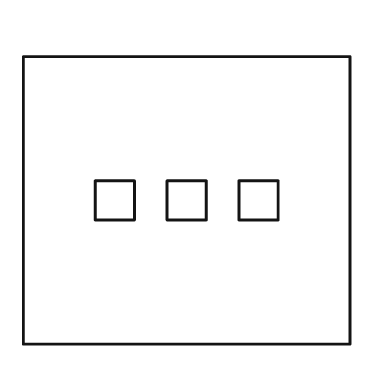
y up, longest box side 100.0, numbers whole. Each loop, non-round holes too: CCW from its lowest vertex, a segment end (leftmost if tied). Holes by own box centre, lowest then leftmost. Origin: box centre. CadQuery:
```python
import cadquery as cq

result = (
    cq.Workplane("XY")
    .moveTo(-50.0, -44.0)
    .lineTo(50.0, -44.0)
    .lineTo(50.0, 44.0)
    .lineTo(-50.0, 44.0)
    .close()
    .moveTo(-28.0, -6.0)
    .lineTo(-16.0, -6.0)
    .lineTo(-16.0, 6.0)
    .lineTo(-28.0, 6.0)
    .close()
    .moveTo(-6.0, -6.0)
    .lineTo(6.0, -6.0)
    .lineTo(6.0, 6.0)
    .lineTo(-6.0, 6.0)
    .close()
    .moveTo(16.0, -6.0)
    .lineTo(28.0, -6.0)
    .lineTo(28.0, 6.0)
    .lineTo(16.0, 6.0)
    .close()
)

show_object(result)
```